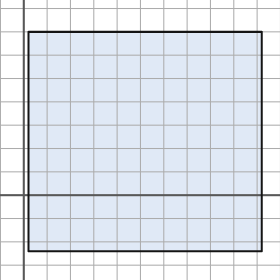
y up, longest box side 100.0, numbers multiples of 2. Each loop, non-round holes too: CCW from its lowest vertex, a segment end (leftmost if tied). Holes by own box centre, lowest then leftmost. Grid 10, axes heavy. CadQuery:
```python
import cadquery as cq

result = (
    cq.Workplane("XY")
    .moveTo(2.0, -24.0)
    .lineTo(102.0, -24.0)
    .lineTo(102.0, 70.0)
    .lineTo(2.0, 70.0)
    .close()
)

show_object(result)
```